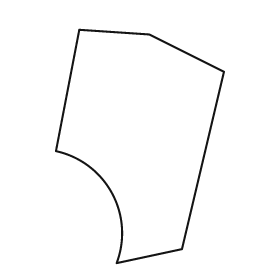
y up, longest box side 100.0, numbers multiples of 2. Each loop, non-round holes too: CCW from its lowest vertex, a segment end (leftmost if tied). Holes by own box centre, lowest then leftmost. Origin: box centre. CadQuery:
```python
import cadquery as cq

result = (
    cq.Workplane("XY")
    .moveTo(-10.0, -50.0)
    .lineTo(18.0, -44.0)
    .lineTo(36.0, 32.0)
    .lineTo(4.0, 48.0)
    .lineTo(-26.0, 50.0)
    .lineTo(-36.0, -2.0)
    .threePointArc((-12.0, -20.0), (-10.0, -50.0))
    .close()
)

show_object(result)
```